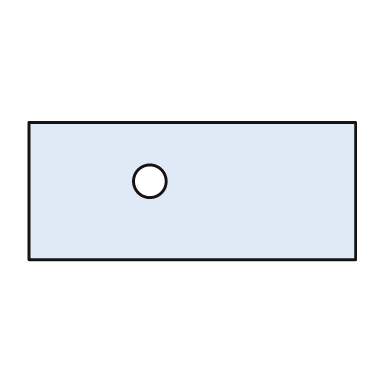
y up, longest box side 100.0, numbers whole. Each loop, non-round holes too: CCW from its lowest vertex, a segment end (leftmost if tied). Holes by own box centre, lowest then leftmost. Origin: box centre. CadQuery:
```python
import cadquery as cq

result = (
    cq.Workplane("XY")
    .moveTo(-50.0, -21.0)
    .lineTo(50.0, -21.0)
    .lineTo(50.0, 21.0)
    .lineTo(-50.0, 21.0)
    .close()
    .moveTo(-13.0, 3.0)
    .circle(5.0)
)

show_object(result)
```